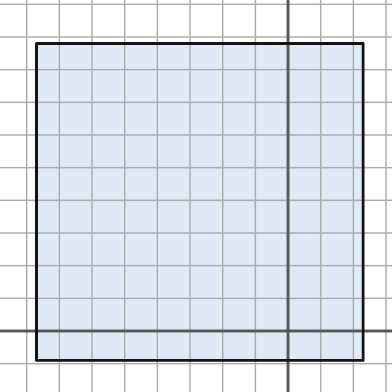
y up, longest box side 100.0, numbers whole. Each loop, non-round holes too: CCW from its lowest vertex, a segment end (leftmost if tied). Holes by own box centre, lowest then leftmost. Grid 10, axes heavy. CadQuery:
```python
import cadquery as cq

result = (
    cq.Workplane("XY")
    .moveTo(-77.0, -9.0)
    .lineTo(23.0, -9.0)
    .lineTo(23.0, 88.0)
    .lineTo(-77.0, 88.0)
    .close()
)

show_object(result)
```